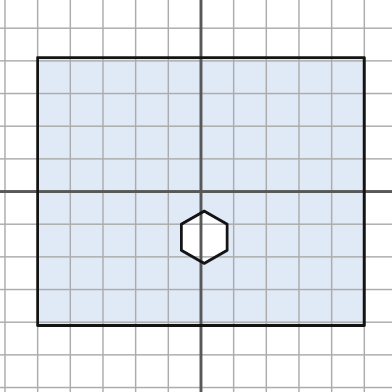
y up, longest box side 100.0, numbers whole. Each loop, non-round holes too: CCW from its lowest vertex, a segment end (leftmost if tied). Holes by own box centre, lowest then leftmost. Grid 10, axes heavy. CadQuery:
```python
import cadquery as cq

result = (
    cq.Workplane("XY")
    .moveTo(-50.0, -41.0)
    .lineTo(50.0, -41.0)
    .lineTo(50.0, 41.0)
    .lineTo(-50.0, 41.0)
    .close()
    .moveTo(1.0, -22.0)
    .lineTo(8.0, -18.0)
    .lineTo(8.0, -10.0)
    .lineTo(1.0, -6.0)
    .lineTo(-6.0, -10.0)
    .lineTo(-6.0, -18.0)
    .close()
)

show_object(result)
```